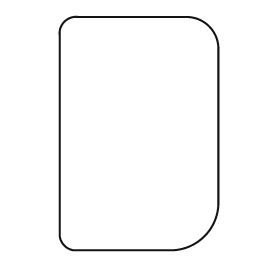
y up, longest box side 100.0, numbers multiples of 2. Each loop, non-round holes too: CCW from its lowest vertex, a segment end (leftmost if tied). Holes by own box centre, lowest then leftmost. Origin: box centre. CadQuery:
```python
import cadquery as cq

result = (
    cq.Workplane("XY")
    .moveTo(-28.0, -50.0)
    .lineTo(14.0, -50.0)
    .threePointArc((28.0, -44.0), (34.0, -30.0))
    .lineTo(34.0, 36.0)
    .threePointArc((30.0, 46.0), (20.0, 50.0))
    .lineTo(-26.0, 50.0)
    .threePointArc((-32.0, 48.0), (-34.0, 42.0))
    .lineTo(-34.0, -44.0)
    .threePointArc((-32.0, -48.0), (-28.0, -50.0))
    .close()
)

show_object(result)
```